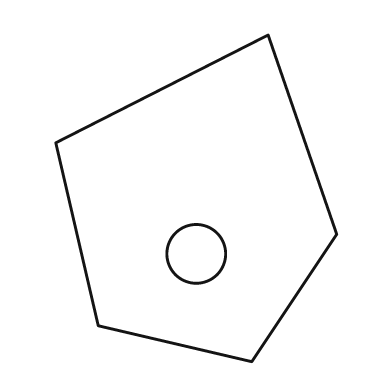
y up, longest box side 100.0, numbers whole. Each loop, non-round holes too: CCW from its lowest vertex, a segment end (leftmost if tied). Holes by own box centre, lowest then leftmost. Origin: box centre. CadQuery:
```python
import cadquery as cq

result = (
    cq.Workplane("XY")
    .moveTo(17.0, -50.0)
    .lineTo(43.0, -11.0)
    .lineTo(22.0, 50.0)
    .lineTo(-43.0, 17.0)
    .lineTo(-30.0, -39.0)
    .close()
    .moveTo(0.0, -17.0)
    .circle(9.0)
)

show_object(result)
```